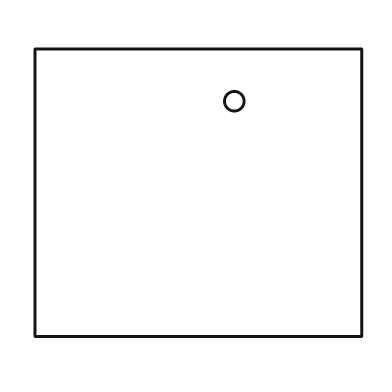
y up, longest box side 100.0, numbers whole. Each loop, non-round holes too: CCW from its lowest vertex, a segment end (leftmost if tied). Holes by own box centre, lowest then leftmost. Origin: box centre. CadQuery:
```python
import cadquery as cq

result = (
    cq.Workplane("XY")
    .moveTo(-50.0, -44.0)
    .lineTo(50.0, -44.0)
    .lineTo(50.0, 44.0)
    .lineTo(-50.0, 44.0)
    .close()
    .moveTo(11.0, 28.0)
    .circle(3.0)
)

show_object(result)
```